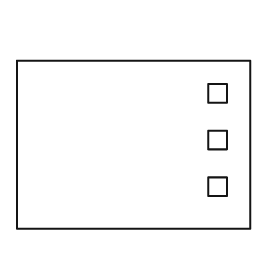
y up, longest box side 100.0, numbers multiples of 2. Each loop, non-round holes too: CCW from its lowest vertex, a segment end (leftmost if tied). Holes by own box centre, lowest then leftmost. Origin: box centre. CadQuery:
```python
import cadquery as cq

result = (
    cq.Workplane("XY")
    .moveTo(-50.0, -36.0)
    .lineTo(50.0, -36.0)
    .lineTo(50.0, 36.0)
    .lineTo(-50.0, 36.0)
    .close()
    .moveTo(32.0, -22.0)
    .lineTo(40.0, -22.0)
    .lineTo(40.0, -14.0)
    .lineTo(32.0, -14.0)
    .close()
    .moveTo(32.0, -2.0)
    .lineTo(40.0, -2.0)
    .lineTo(40.0, 6.0)
    .lineTo(32.0, 6.0)
    .close()
    .moveTo(32.0, 18.0)
    .lineTo(40.0, 18.0)
    .lineTo(40.0, 26.0)
    .lineTo(32.0, 26.0)
    .close()
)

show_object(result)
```